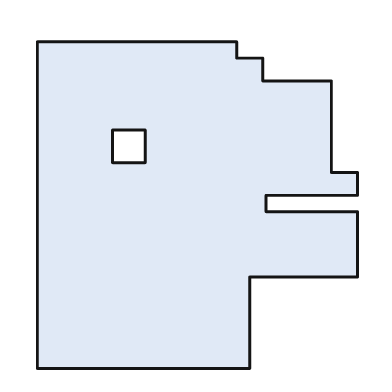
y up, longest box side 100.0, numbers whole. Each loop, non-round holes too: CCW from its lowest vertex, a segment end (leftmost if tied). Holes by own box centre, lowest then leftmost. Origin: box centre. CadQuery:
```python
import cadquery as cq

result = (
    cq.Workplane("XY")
    .moveTo(-49.0, -50.0)
    .lineTo(16.0, -50.0)
    .lineTo(16.0, -22.0)
    .lineTo(49.0, -22.0)
    .lineTo(49.0, -2.0)
    .lineTo(21.0, -2.0)
    .lineTo(21.0, 3.0)
    .lineTo(49.0, 3.0)
    .lineTo(49.0, 10.0)
    .lineTo(41.0, 10.0)
    .lineTo(41.0, 38.0)
    .lineTo(20.0, 38.0)
    .lineTo(20.0, 45.0)
    .lineTo(12.0, 45.0)
    .lineTo(12.0, 50.0)
    .lineTo(-49.0, 50.0)
    .close()
    .moveTo(-26.0, 13.0)
    .lineTo(-16.0, 13.0)
    .lineTo(-16.0, 23.0)
    .lineTo(-26.0, 23.0)
    .close()
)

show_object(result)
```